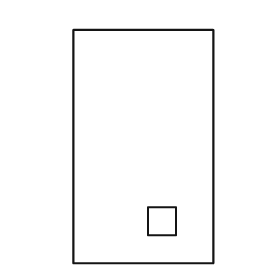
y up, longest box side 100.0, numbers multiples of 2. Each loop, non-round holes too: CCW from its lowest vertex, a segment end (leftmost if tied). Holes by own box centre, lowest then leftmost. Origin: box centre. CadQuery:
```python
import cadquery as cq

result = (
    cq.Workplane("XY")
    .moveTo(-30.0, -50.0)
    .lineTo(30.0, -50.0)
    .lineTo(30.0, 50.0)
    .lineTo(-30.0, 50.0)
    .close()
    .moveTo(2.0, -38.0)
    .lineTo(14.0, -38.0)
    .lineTo(14.0, -26.0)
    .lineTo(2.0, -26.0)
    .close()
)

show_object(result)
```